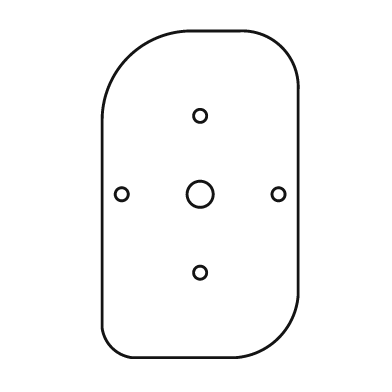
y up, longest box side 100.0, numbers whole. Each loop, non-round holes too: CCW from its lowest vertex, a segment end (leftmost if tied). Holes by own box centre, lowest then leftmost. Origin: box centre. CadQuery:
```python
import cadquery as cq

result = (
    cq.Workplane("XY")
    .moveTo(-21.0, -50.0)
    .lineTo(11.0, -50.0)
    .threePointArc((24.0, -44.0), (30.0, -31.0))
    .lineTo(30.0, 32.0)
    .threePointArc((25.0, 45.0), (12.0, 50.0))
    .lineTo(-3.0, 50.0)
    .threePointArc((-22.0, 42.0), (-30.0, 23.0))
    .lineTo(-30.0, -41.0)
    .threePointArc((-27.0, -47.0), (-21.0, -50.0))
    .close()
    .moveTo(0.0, -24.0)
    .circle(2.0)
    .moveTo(-24.0, 0.0)
    .circle(2.0)
    .moveTo(0.0, 0.0)
    .circle(4.0)
    .moveTo(24.0, 0.0)
    .circle(2.0)
    .moveTo(0.0, 24.0)
    .circle(2.0)
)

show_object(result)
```